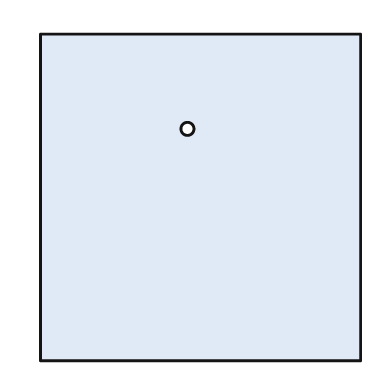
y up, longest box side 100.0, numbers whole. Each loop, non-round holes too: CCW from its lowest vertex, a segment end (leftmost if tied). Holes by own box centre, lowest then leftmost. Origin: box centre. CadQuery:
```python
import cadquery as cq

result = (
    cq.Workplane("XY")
    .moveTo(-49.0, -50.0)
    .lineTo(49.0, -50.0)
    .lineTo(49.0, 50.0)
    .lineTo(-49.0, 50.0)
    .close()
    .moveTo(-4.0, 21.0)
    .circle(2.0)
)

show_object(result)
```